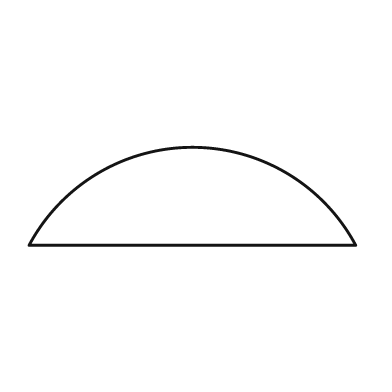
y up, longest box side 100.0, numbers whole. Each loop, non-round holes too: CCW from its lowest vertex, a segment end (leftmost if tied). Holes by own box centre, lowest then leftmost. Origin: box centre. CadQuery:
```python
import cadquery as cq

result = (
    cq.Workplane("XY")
    .moveTo(-50.0, -15.0)
    .lineTo(50.0, -15.0)
    .threePointArc((0.0, 15.0), (-50.0, -15.0))
    .close()
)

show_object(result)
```